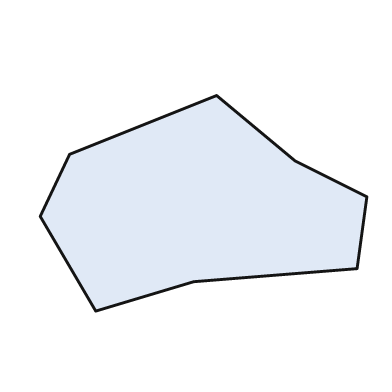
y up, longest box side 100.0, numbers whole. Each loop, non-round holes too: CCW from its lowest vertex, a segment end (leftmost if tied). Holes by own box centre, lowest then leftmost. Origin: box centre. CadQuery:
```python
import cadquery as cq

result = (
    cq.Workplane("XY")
    .moveTo(-33.0, -33.0)
    .lineTo(-3.0, -24.0)
    .lineTo(47.0, -20.0)
    .lineTo(50.0, 2.0)
    .lineTo(28.0, 13.0)
    .lineTo(4.0, 33.0)
    .lineTo(-41.0, 15.0)
    .lineTo(-50.0, -4.0)
    .close()
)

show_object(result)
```